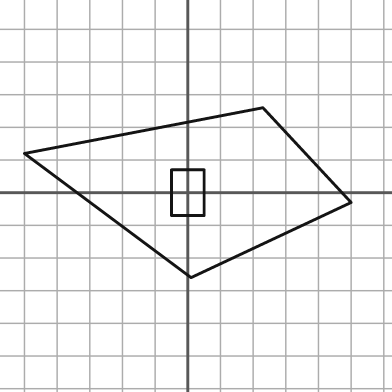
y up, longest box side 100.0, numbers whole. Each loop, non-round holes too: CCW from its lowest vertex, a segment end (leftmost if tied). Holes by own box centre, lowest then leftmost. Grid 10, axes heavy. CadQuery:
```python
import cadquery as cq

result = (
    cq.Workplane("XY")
    .moveTo(1.0, -26.0)
    .lineTo(50.0, -3.0)
    .lineTo(23.0, 26.0)
    .lineTo(-50.0, 12.0)
    .close()
    .moveTo(-5.0, -7.0)
    .lineTo(5.0, -7.0)
    .lineTo(5.0, 7.0)
    .lineTo(-5.0, 7.0)
    .close()
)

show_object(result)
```